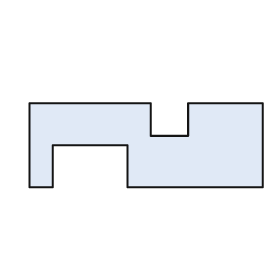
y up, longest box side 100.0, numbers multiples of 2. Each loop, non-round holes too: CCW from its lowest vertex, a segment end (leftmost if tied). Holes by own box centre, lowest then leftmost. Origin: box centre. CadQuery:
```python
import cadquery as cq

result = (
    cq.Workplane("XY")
    .moveTo(-50.0, -18.0)
    .lineTo(-40.0, -18.0)
    .lineTo(-40.0, 0.0)
    .lineTo(-8.0, 0.0)
    .lineTo(-8.0, -18.0)
    .lineTo(50.0, -18.0)
    .lineTo(50.0, 18.0)
    .lineTo(18.0, 18.0)
    .lineTo(18.0, 4.0)
    .lineTo(2.0, 4.0)
    .lineTo(2.0, 18.0)
    .lineTo(-50.0, 18.0)
    .close()
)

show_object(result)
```